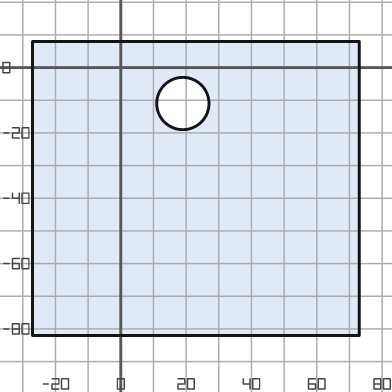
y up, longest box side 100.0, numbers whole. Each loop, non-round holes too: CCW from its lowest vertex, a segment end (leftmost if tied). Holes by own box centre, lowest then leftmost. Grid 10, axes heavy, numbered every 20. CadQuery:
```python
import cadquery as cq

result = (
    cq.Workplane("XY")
    .moveTo(-27.0, -82.0)
    .lineTo(73.0, -82.0)
    .lineTo(73.0, 8.0)
    .lineTo(-27.0, 8.0)
    .close()
    .moveTo(19.0, -11.0)
    .circle(8.0)
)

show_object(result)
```